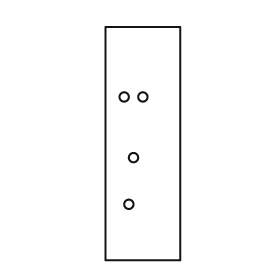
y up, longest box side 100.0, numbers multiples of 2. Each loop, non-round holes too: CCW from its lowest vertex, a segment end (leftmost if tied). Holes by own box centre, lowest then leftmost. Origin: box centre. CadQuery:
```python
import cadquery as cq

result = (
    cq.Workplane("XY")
    .moveTo(-16.0, -50.0)
    .lineTo(16.0, -50.0)
    .lineTo(16.0, 50.0)
    .lineTo(-16.0, 50.0)
    .close()
    .moveTo(-6.0, -26.0)
    .circle(2.0)
    .moveTo(-4.0, -6.0)
    .circle(2.0)
    .moveTo(-8.0, 20.0)
    .circle(2.0)
    .moveTo(0.0, 20.0)
    .circle(2.0)
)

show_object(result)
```